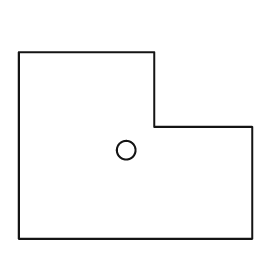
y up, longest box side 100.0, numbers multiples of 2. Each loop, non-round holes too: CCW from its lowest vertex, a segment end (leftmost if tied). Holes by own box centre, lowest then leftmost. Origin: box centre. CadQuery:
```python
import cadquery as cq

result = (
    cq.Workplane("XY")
    .moveTo(-50.0, -40.0)
    .lineTo(50.0, -40.0)
    .lineTo(50.0, 8.0)
    .lineTo(8.0, 8.0)
    .lineTo(8.0, 40.0)
    .lineTo(-50.0, 40.0)
    .close()
    .moveTo(-4.0, -2.0)
    .circle(4.0)
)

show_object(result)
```